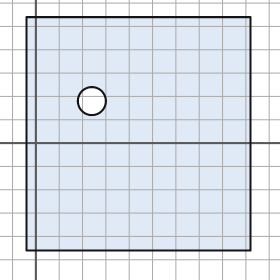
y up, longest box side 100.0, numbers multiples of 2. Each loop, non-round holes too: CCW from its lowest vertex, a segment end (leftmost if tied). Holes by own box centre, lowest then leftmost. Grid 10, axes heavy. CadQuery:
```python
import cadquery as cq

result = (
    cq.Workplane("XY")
    .moveTo(-4.0, -46.0)
    .lineTo(92.0, -46.0)
    .lineTo(92.0, 54.0)
    .lineTo(-4.0, 54.0)
    .close()
    .moveTo(24.0, 18.0)
    .circle(6.0)
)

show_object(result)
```